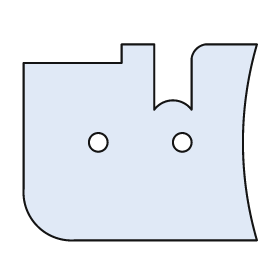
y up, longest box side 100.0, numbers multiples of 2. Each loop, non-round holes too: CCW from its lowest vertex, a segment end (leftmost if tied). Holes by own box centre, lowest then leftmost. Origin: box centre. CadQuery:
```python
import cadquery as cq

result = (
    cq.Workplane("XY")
    .moveTo(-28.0, -42.0)
    .lineTo(50.0, -42.0)
    .threePointArc((44.0, 0.0), (50.0, 42.0))
    .lineTo(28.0, 42.0)
    .threePointArc((24.0, 40.0), (22.0, 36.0))
    .lineTo(22.0, 14.0)
    .threePointArc((14.0, 18.0), (6.0, 14.0))
    .lineTo(6.0, 42.0)
    .lineTo(-8.0, 42.0)
    .lineTo(-8.0, 34.0)
    .lineTo(-50.0, 34.0)
    .lineTo(-50.0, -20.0)
    .threePointArc((-44.0, -36.0), (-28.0, -42.0))
    .close()
    .moveTo(-18.0, 0.0)
    .circle(4.0)
    .moveTo(18.0, 0.0)
    .circle(4.0)
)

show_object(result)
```